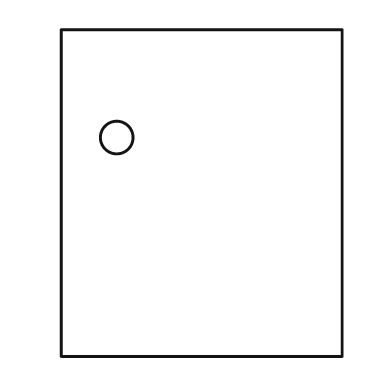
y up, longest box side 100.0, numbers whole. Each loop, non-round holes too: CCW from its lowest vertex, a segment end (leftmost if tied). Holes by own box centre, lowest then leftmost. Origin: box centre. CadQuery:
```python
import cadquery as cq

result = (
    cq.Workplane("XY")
    .moveTo(-43.0, -50.0)
    .lineTo(43.0, -50.0)
    .lineTo(43.0, 50.0)
    .lineTo(-43.0, 50.0)
    .close()
    .moveTo(-26.0, 17.0)
    .circle(5.0)
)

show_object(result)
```